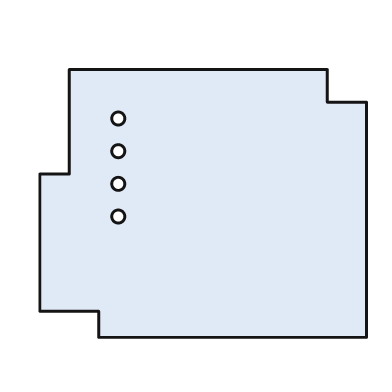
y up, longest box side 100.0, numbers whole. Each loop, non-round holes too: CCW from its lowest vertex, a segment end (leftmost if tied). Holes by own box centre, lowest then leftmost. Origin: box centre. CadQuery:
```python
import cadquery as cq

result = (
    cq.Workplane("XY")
    .moveTo(-32.0, -41.0)
    .lineTo(50.0, -41.0)
    .lineTo(50.0, 31.0)
    .lineTo(38.0, 31.0)
    .lineTo(38.0, 41.0)
    .lineTo(-41.0, 41.0)
    .lineTo(-41.0, 9.0)
    .lineTo(-50.0, 9.0)
    .lineTo(-50.0, -33.0)
    .lineTo(-32.0, -33.0)
    .close()
    .moveTo(-26.0, -4.0)
    .circle(2.0)
    .moveTo(-26.0, 6.0)
    .circle(2.0)
    .moveTo(-26.0, 16.0)
    .circle(2.0)
    .moveTo(-26.0, 26.0)
    .circle(2.0)
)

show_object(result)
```